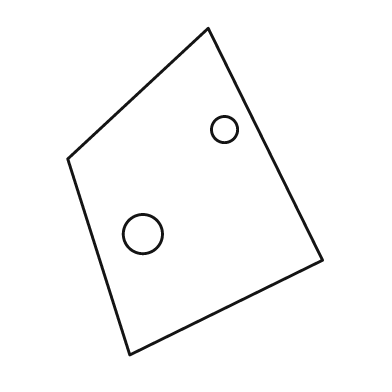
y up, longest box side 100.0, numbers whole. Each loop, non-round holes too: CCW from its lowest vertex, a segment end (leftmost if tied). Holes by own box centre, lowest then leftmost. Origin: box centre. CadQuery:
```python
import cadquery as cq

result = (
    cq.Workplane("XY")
    .moveTo(-20.0, -50.0)
    .lineTo(39.0, -21.0)
    .lineTo(4.0, 50.0)
    .lineTo(-39.0, 10.0)
    .close()
    .moveTo(-16.0, -13.0)
    .circle(6.0)
    .moveTo(9.0, 19.0)
    .circle(4.0)
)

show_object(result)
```